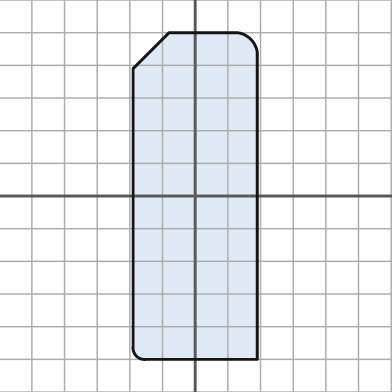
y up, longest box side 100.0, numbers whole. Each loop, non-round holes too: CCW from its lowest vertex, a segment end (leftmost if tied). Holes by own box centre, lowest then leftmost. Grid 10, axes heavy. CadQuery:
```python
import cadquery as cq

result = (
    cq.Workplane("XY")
    .moveTo(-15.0, -50.0)
    .lineTo(19.0, -50.0)
    .lineTo(19.0, 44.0)
    .threePointArc((17.0, 48.0), (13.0, 50.0))
    .lineTo(-8.0, 50.0)
    .lineTo(-19.0, 39.0)
    .lineTo(-19.0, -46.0)
    .threePointArc((-18.0, -49.0), (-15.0, -50.0))
    .close()
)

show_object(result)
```